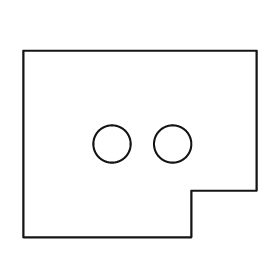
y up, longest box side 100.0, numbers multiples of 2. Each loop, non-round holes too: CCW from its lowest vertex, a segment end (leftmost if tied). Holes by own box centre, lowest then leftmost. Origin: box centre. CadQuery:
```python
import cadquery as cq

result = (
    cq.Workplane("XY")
    .moveTo(-50.0, -40.0)
    .lineTo(22.0, -40.0)
    .lineTo(22.0, -20.0)
    .lineTo(50.0, -20.0)
    .lineTo(50.0, 40.0)
    .lineTo(-50.0, 40.0)
    .close()
    .moveTo(-12.0, 0.0)
    .circle(8.0)
    .moveTo(14.0, 0.0)
    .circle(8.0)
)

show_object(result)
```